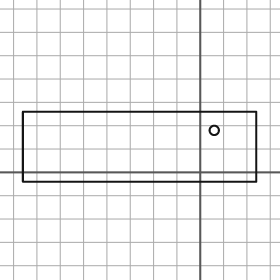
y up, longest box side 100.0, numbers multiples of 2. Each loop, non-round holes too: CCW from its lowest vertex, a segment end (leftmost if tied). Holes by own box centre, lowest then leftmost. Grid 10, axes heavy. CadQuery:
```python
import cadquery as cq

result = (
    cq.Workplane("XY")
    .moveTo(-76.0, -4.0)
    .lineTo(24.0, -4.0)
    .lineTo(24.0, 26.0)
    .lineTo(-76.0, 26.0)
    .close()
    .moveTo(6.0, 18.0)
    .circle(2.0)
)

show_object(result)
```